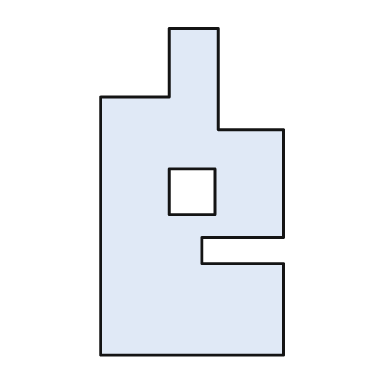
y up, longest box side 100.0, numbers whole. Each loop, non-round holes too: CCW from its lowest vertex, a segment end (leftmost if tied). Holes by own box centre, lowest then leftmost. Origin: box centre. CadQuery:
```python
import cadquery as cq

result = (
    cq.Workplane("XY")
    .moveTo(-28.0, -50.0)
    .lineTo(28.0, -50.0)
    .lineTo(28.0, -22.0)
    .lineTo(3.0, -22.0)
    .lineTo(3.0, -14.0)
    .lineTo(28.0, -14.0)
    .lineTo(28.0, 19.0)
    .lineTo(8.0, 19.0)
    .lineTo(8.0, 50.0)
    .lineTo(-7.0, 50.0)
    .lineTo(-7.0, 29.0)
    .lineTo(-28.0, 29.0)
    .close()
    .moveTo(-7.0, -7.0)
    .lineTo(7.0, -7.0)
    .lineTo(7.0, 7.0)
    .lineTo(-7.0, 7.0)
    .close()
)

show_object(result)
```